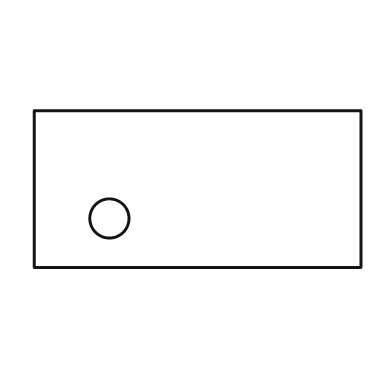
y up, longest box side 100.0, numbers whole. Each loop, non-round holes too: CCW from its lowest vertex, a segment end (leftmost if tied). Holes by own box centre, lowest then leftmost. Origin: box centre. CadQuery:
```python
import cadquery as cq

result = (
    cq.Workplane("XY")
    .moveTo(-50.0, -24.0)
    .lineTo(50.0, -24.0)
    .lineTo(50.0, 24.0)
    .lineTo(-50.0, 24.0)
    .close()
    .moveTo(-27.0, -9.0)
    .circle(6.0)
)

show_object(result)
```